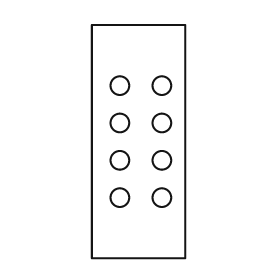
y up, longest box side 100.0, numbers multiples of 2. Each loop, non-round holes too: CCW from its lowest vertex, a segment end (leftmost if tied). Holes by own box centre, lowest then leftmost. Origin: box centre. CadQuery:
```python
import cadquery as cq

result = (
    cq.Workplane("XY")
    .moveTo(-20.0, -50.0)
    .lineTo(20.0, -50.0)
    .lineTo(20.0, 50.0)
    .lineTo(-20.0, 50.0)
    .close()
    .moveTo(-8.0, -24.0)
    .circle(4.0)
    .moveTo(10.0, -24.0)
    .circle(4.0)
    .moveTo(-8.0, -8.0)
    .circle(4.0)
    .moveTo(10.0, -8.0)
    .circle(4.0)
    .moveTo(-8.0, 8.0)
    .circle(4.0)
    .moveTo(10.0, 8.0)
    .circle(4.0)
    .moveTo(-8.0, 24.0)
    .circle(4.0)
    .moveTo(10.0, 24.0)
    .circle(4.0)
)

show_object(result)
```